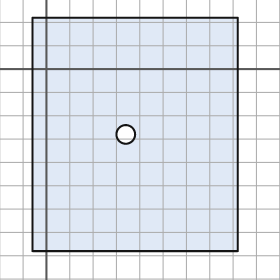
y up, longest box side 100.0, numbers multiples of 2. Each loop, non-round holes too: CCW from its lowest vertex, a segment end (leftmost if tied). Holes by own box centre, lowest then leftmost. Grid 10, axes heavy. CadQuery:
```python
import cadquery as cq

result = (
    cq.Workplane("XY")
    .moveTo(-6.0, -78.0)
    .lineTo(82.0, -78.0)
    .lineTo(82.0, 22.0)
    .lineTo(-6.0, 22.0)
    .close()
    .moveTo(34.0, -28.0)
    .circle(4.0)
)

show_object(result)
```